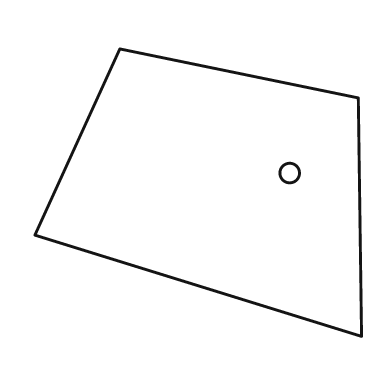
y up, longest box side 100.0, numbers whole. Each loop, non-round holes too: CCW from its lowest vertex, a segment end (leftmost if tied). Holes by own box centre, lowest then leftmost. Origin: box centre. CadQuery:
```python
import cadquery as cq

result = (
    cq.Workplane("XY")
    .moveTo(50.0, -44.0)
    .lineTo(49.0, 29.0)
    .lineTo(-24.0, 44.0)
    .lineTo(-50.0, -13.0)
    .close()
    .moveTo(28.0, 6.0)
    .circle(3.0)
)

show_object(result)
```